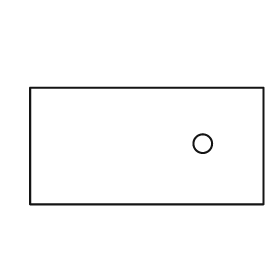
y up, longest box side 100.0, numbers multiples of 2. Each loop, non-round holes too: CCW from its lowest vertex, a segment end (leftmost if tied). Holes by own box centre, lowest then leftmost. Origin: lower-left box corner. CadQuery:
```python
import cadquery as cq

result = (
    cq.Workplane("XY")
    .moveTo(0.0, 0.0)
    .lineTo(100.0, 0.0)
    .lineTo(100.0, 50.0)
    .lineTo(0.0, 50.0)
    .close()
    .moveTo(74.0, 26.0)
    .circle(4.0)
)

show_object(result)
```